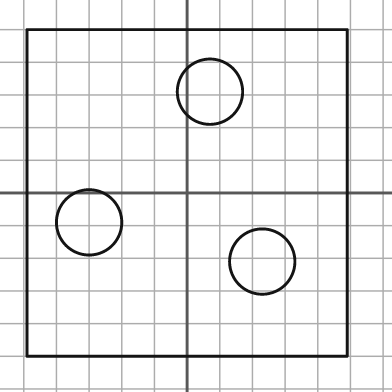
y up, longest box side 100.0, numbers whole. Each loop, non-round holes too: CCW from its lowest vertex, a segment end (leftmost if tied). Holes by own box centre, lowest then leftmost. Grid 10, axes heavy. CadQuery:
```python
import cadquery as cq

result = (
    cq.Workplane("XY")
    .moveTo(-49.0, -50.0)
    .lineTo(49.0, -50.0)
    .lineTo(49.0, 50.0)
    .lineTo(-49.0, 50.0)
    .close()
    .moveTo(23.0, -21.0)
    .circle(10.0)
    .moveTo(-30.0, -9.0)
    .circle(10.0)
    .moveTo(7.0, 31.0)
    .circle(10.0)
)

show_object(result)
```